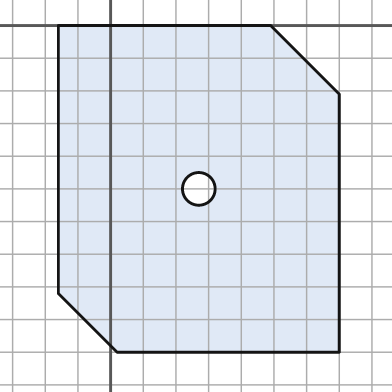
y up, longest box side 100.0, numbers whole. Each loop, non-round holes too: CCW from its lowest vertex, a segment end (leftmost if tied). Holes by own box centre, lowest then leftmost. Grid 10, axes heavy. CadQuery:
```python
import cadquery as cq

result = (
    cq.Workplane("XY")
    .moveTo(2.0, -100.0)
    .lineTo(70.0, -100.0)
    .lineTo(70.0, -21.0)
    .lineTo(49.0, 0.0)
    .lineTo(-16.0, 0.0)
    .lineTo(-16.0, -82.0)
    .close()
    .moveTo(27.0, -50.0)
    .circle(5.0)
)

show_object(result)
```